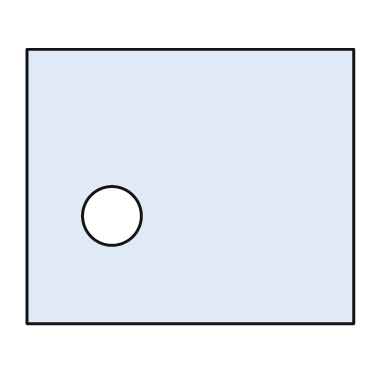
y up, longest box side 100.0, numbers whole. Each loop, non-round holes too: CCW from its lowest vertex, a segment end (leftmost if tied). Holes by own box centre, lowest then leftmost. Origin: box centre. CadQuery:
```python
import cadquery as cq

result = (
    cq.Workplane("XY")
    .moveTo(-50.0, -42.0)
    .lineTo(50.0, -42.0)
    .lineTo(50.0, 42.0)
    .lineTo(-50.0, 42.0)
    .close()
    .moveTo(-24.0, -9.0)
    .circle(9.0)
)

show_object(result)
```